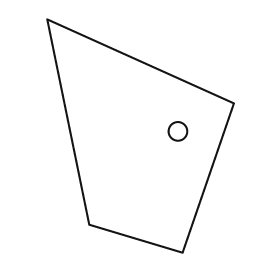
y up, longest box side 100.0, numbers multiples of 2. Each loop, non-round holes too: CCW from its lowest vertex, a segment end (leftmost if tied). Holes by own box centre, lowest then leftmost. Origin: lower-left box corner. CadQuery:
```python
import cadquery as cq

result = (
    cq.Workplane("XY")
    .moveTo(58.0, 0.0)
    .lineTo(80.0, 64.0)
    .lineTo(0.0, 100.0)
    .lineTo(18.0, 12.0)
    .close()
    .moveTo(56.0, 52.0)
    .circle(4.0)
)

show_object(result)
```